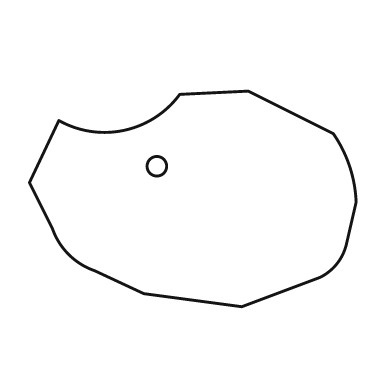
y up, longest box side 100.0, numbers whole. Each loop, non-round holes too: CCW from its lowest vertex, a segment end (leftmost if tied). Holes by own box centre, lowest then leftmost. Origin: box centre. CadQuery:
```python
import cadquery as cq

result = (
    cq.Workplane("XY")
    .moveTo(15.0, -33.0)
    .lineTo(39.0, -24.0)
    .threePointArc((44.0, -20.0), (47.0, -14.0))
    .lineTo(50.0, -1.0)
    .threePointArc((48.0, 10.0), (43.0, 20.0))
    .lineTo(17.0, 33.0)
    .lineTo(-4.0, 32.0)
    .threePointArc((-21.0, 21.0), (-41.0, 24.0))
    .lineTo(-50.0, 5.0)
    .lineTo(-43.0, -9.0)
    .threePointArc((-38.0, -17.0), (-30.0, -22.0))
    .lineTo(-15.0, -29.0)
    .close()
    .moveTo(-11.0, 10.0)
    .circle(3.0)
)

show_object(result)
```